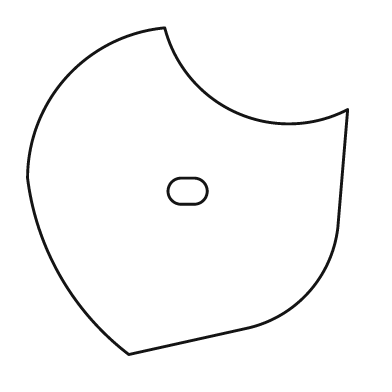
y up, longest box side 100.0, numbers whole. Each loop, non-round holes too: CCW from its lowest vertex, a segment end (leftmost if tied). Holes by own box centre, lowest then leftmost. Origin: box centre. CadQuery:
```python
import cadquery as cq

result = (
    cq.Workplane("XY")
    .moveTo(-18.0, -50.0)
    .lineTo(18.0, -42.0)
    .threePointArc((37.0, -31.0), (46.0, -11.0))
    .lineTo(49.0, 25.0)
    .threePointArc((15.0, 24.0), (-7.0, 50.0))
    .threePointArc((-37.0, 35.0), (-49.0, 4.0))
    .threePointArc((-39.0, -26.0), (-18.0, -50.0))
    .close()
    .moveTo(-2.0, -4.0)
    .lineTo(2.0, -4.0)
    .threePointArc((6.0, 0.0), (2.0, 4.0))
    .lineTo(-2.0, 4.0)
    .threePointArc((-6.0, 0.0), (-2.0, -4.0))
    .close()
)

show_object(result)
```